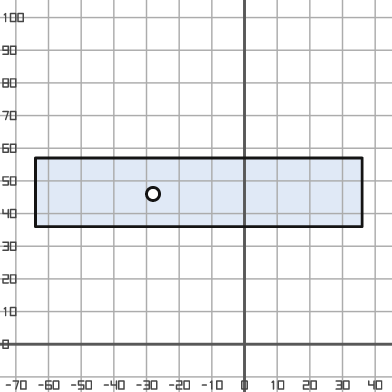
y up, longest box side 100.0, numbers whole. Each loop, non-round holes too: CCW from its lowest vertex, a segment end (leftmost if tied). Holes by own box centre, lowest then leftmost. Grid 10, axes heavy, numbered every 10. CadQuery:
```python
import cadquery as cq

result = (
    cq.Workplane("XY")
    .moveTo(-64.0, 36.0)
    .lineTo(36.0, 36.0)
    .lineTo(36.0, 57.0)
    .lineTo(-64.0, 57.0)
    .close()
    .moveTo(-28.0, 46.0)
    .circle(2.0)
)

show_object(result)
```